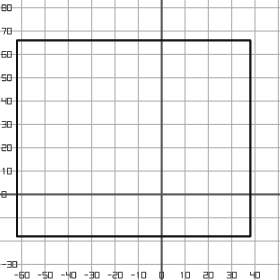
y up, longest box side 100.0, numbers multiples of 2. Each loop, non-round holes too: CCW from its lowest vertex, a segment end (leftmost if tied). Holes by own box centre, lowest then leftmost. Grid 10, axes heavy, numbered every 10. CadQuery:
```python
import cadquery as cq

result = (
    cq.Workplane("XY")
    .moveTo(-62.0, -18.0)
    .lineTo(38.0, -18.0)
    .lineTo(38.0, 66.0)
    .lineTo(-62.0, 66.0)
    .close()
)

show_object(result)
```